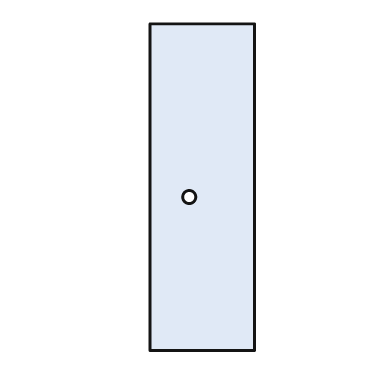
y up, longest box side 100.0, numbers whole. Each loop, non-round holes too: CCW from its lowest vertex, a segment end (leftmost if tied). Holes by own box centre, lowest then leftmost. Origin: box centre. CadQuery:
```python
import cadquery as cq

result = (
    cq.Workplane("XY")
    .moveTo(-16.0, -50.0)
    .lineTo(16.0, -50.0)
    .lineTo(16.0, 50.0)
    .lineTo(-16.0, 50.0)
    .close()
    .moveTo(-4.0, -3.0)
    .circle(2.0)
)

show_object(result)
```